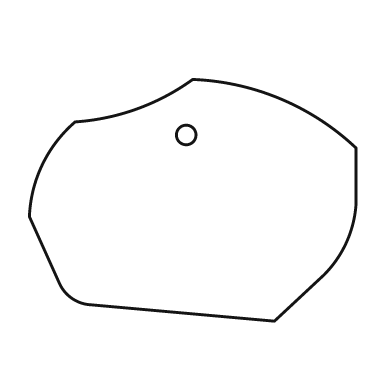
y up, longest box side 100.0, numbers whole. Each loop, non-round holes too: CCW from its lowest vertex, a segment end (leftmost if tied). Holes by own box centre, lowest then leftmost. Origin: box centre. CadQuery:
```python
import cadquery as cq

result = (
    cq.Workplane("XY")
    .moveTo(25.0, -37.0)
    .lineTo(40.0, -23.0)
    .threePointArc((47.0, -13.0), (50.0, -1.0))
    .lineTo(50.0, 16.0)
    .threePointArc((27.0, 31.0), (0.0, 37.0))
    .threePointArc((-17.0, 28.0), (-36.0, 24.0))
    .threePointArc((-46.0, 11.0), (-50.0, -5.0))
    .lineTo(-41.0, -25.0)
    .threePointArc((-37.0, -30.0), (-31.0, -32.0))
    .close()
    .moveTo(-2.0, 20.0)
    .circle(3.0)
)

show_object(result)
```